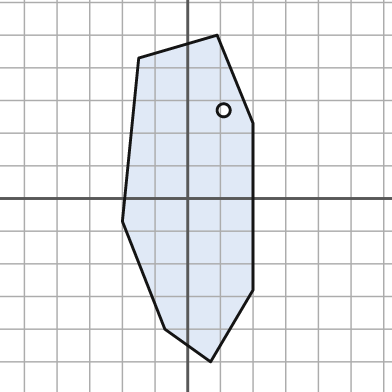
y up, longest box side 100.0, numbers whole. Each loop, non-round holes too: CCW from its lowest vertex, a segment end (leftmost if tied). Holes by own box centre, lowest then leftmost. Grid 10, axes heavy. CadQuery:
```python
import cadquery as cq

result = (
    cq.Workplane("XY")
    .moveTo(7.0, -50.0)
    .lineTo(20.0, -28.0)
    .lineTo(20.0, 23.0)
    .lineTo(9.0, 50.0)
    .lineTo(-15.0, 43.0)
    .lineTo(-20.0, -7.0)
    .lineTo(-7.0, -40.0)
    .close()
    .moveTo(11.0, 27.0)
    .circle(2.0)
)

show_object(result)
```